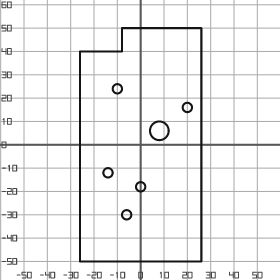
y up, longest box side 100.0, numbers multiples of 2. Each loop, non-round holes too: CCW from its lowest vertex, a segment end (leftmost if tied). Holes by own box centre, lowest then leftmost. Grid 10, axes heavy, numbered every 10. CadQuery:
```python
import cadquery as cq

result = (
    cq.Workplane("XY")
    .moveTo(-26.0, -50.0)
    .lineTo(26.0, -50.0)
    .lineTo(26.0, 50.0)
    .lineTo(-8.0, 50.0)
    .lineTo(-8.0, 40.0)
    .lineTo(-26.0, 40.0)
    .close()
    .moveTo(-6.0, -30.0)
    .circle(2.0)
    .moveTo(0.0, -18.0)
    .circle(2.0)
    .moveTo(-14.0, -12.0)
    .circle(2.0)
    .moveTo(8.0, 6.0)
    .circle(4.0)
    .moveTo(20.0, 16.0)
    .circle(2.0)
    .moveTo(-10.0, 24.0)
    .circle(2.0)
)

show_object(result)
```